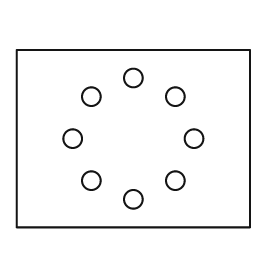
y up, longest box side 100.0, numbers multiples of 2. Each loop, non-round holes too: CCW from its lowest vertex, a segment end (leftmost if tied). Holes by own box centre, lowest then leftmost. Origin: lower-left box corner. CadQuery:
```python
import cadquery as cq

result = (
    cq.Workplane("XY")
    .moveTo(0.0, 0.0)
    .lineTo(100.0, 0.0)
    .lineTo(100.0, 76.0)
    .lineTo(0.0, 76.0)
    .close()
    .moveTo(50.0, 12.0)
    .circle(4.0)
    .moveTo(32.0, 20.0)
    .circle(4.0)
    .moveTo(68.0, 20.0)
    .circle(4.0)
    .moveTo(24.0, 38.0)
    .circle(4.0)
    .moveTo(76.0, 38.0)
    .circle(4.0)
    .moveTo(32.0, 56.0)
    .circle(4.0)
    .moveTo(68.0, 56.0)
    .circle(4.0)
    .moveTo(50.0, 64.0)
    .circle(4.0)
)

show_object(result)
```